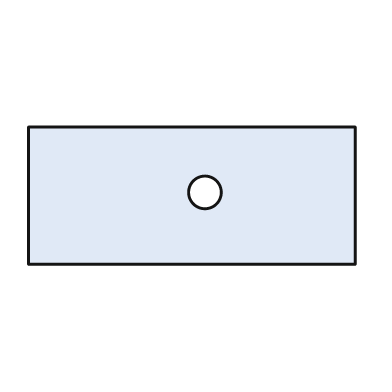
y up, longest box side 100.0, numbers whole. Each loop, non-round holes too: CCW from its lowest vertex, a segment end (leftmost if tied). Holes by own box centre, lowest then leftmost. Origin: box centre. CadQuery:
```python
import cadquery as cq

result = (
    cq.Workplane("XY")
    .moveTo(-50.0, -21.0)
    .lineTo(50.0, -21.0)
    .lineTo(50.0, 21.0)
    .lineTo(-50.0, 21.0)
    .close()
    .moveTo(4.0, 1.0)
    .circle(5.0)
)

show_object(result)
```